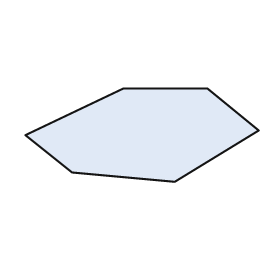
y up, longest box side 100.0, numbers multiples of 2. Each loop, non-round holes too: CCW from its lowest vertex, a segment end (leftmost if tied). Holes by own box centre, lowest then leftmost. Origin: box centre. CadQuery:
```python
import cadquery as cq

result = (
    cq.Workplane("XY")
    .moveTo(14.0, -20.0)
    .lineTo(50.0, 2.0)
    .lineTo(28.0, 20.0)
    .lineTo(-8.0, 20.0)
    .lineTo(-50.0, 0.0)
    .lineTo(-30.0, -16.0)
    .close()
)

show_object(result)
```